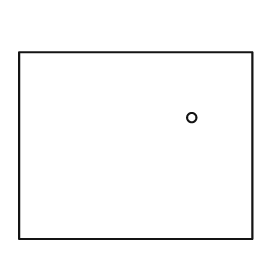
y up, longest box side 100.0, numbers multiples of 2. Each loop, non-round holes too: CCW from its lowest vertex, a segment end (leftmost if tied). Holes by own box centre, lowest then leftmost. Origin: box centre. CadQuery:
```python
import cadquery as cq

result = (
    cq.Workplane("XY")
    .moveTo(-50.0, -40.0)
    .lineTo(50.0, -40.0)
    .lineTo(50.0, 40.0)
    .lineTo(-50.0, 40.0)
    .close()
    .moveTo(24.0, 12.0)
    .circle(2.0)
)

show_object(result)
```